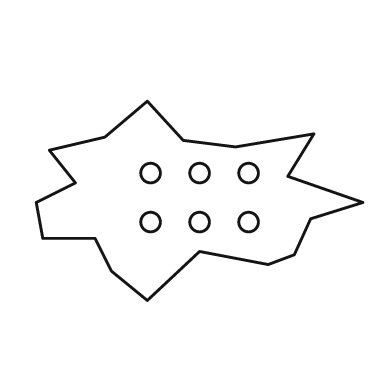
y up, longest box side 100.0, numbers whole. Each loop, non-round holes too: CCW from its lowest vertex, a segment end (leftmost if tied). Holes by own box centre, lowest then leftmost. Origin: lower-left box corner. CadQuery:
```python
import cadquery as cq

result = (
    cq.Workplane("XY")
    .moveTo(34.0, 0.0)
    .lineTo(50.0, 15.0)
    .lineTo(71.0, 11.0)
    .lineTo(79.0, 14.0)
    .lineTo(84.0, 25.0)
    .lineTo(100.0, 30.0)
    .lineTo(77.0, 38.0)
    .lineTo(85.0, 51.0)
    .lineTo(61.0, 47.0)
    .lineTo(45.0, 49.0)
    .lineTo(34.0, 61.0)
    .lineTo(21.0, 50.0)
    .lineTo(4.0, 46.0)
    .lineTo(12.0, 36.0)
    .lineTo(0.0, 30.0)
    .lineTo(2.0, 19.0)
    .lineTo(18.0, 19.0)
    .lineTo(23.0, 9.0)
    .close()
    .moveTo(35.0, 24.0)
    .circle(3.0)
    .moveTo(50.0, 24.0)
    .circle(3.0)
    .moveTo(65.0, 24.0)
    .circle(3.0)
    .moveTo(35.0, 39.0)
    .circle(3.0)
    .moveTo(50.0, 39.0)
    .circle(3.0)
    .moveTo(65.0, 39.0)
    .circle(3.0)
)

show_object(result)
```